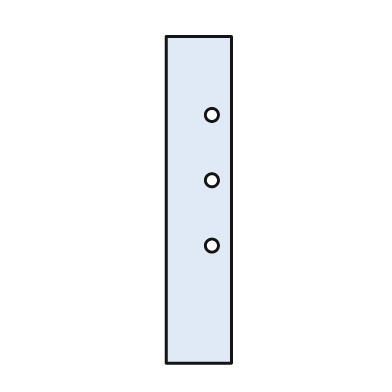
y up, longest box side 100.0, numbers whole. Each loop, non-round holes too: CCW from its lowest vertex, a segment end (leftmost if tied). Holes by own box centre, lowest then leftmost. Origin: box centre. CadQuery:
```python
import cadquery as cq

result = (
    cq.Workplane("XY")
    .moveTo(-10.0, -50.0)
    .lineTo(10.0, -50.0)
    .lineTo(10.0, 50.0)
    .lineTo(-10.0, 50.0)
    .close()
    .moveTo(4.0, -14.0)
    .circle(2.0)
    .moveTo(4.0, 6.0)
    .circle(2.0)
    .moveTo(4.0, 26.0)
    .circle(2.0)
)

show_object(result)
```